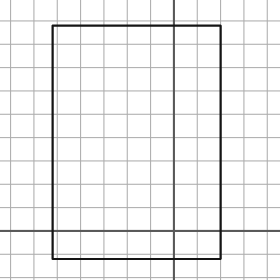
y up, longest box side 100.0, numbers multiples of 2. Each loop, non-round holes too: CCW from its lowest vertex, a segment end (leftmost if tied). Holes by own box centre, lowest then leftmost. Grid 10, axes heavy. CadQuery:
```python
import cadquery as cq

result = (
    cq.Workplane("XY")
    .moveTo(-52.0, -12.0)
    .lineTo(20.0, -12.0)
    .lineTo(20.0, 88.0)
    .lineTo(-52.0, 88.0)
    .close()
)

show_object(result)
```